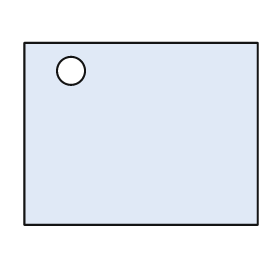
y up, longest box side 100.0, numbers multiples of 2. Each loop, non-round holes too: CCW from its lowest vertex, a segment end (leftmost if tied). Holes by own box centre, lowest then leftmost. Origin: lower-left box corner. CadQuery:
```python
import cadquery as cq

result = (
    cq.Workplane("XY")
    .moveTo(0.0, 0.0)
    .lineTo(100.0, 0.0)
    .lineTo(100.0, 78.0)
    .lineTo(0.0, 78.0)
    .close()
    .moveTo(20.0, 66.0)
    .circle(6.0)
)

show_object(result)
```